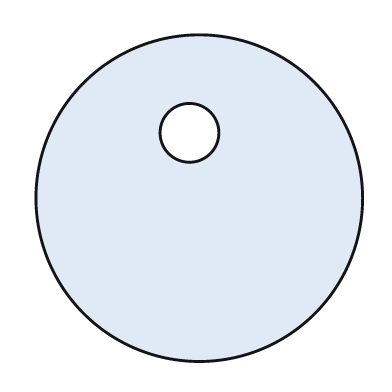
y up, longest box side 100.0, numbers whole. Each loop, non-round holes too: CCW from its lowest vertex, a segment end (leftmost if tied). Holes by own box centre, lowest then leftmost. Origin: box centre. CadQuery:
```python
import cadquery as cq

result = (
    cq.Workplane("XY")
    .moveTo(0.0, 0.0)
    .circle(50.0)
    .moveTo(-3.0, 20.0)
    .circle(9.0)
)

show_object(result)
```